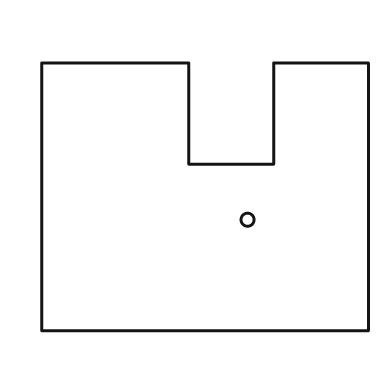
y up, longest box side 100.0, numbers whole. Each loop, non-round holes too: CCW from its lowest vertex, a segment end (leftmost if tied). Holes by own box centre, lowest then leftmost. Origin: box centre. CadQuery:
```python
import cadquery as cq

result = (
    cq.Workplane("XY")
    .moveTo(-50.0, -41.0)
    .lineTo(50.0, -41.0)
    .lineTo(50.0, 41.0)
    .lineTo(21.0, 41.0)
    .lineTo(21.0, 10.0)
    .lineTo(-5.0, 10.0)
    .lineTo(-5.0, 41.0)
    .lineTo(-50.0, 41.0)
    .close()
    .moveTo(13.0, -7.0)
    .circle(2.0)
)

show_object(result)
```